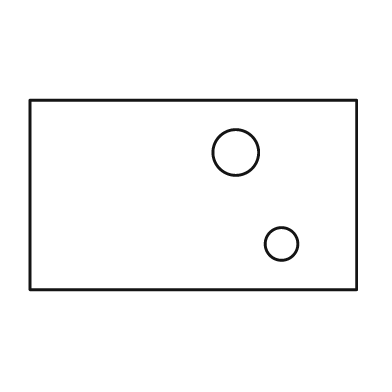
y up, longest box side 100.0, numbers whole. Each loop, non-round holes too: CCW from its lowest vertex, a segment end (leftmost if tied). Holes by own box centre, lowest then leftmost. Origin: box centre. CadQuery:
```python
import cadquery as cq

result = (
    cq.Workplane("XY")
    .moveTo(-50.0, -29.0)
    .lineTo(50.0, -29.0)
    .lineTo(50.0, 29.0)
    .lineTo(-50.0, 29.0)
    .close()
    .moveTo(27.0, -15.0)
    .circle(5.0)
    .moveTo(13.0, 13.0)
    .circle(7.0)
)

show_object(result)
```